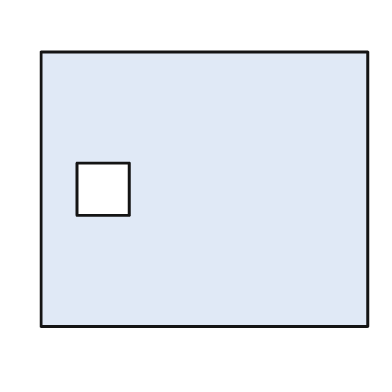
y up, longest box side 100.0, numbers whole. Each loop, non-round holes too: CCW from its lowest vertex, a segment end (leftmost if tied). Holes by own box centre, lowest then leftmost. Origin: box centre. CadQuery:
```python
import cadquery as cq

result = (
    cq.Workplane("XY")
    .moveTo(-50.0, -42.0)
    .lineTo(50.0, -42.0)
    .lineTo(50.0, 42.0)
    .lineTo(-50.0, 42.0)
    .close()
    .moveTo(-39.0, -8.0)
    .lineTo(-23.0, -8.0)
    .lineTo(-23.0, 8.0)
    .lineTo(-39.0, 8.0)
    .close()
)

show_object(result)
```